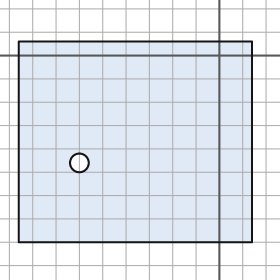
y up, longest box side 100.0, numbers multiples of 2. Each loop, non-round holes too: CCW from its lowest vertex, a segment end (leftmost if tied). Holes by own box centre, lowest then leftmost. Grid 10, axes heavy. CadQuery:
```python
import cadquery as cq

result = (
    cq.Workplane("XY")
    .moveTo(-86.0, -80.0)
    .lineTo(14.0, -80.0)
    .lineTo(14.0, 6.0)
    .lineTo(-86.0, 6.0)
    .close()
    .moveTo(-60.0, -46.0)
    .circle(4.0)
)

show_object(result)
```